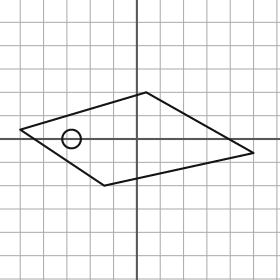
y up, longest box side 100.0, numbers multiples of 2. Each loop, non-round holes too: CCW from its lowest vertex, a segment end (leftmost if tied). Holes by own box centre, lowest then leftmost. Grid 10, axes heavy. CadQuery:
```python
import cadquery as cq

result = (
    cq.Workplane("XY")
    .moveTo(-14.0, -20.0)
    .lineTo(50.0, -6.0)
    .lineTo(4.0, 20.0)
    .lineTo(-50.0, 4.0)
    .close()
    .moveTo(-28.0, 0.0)
    .circle(4.0)
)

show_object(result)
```